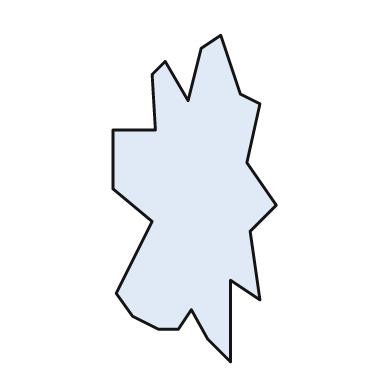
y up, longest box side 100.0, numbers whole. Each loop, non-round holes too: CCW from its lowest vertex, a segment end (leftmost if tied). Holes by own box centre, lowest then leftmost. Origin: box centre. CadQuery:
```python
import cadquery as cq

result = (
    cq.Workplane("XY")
    .moveTo(11.0, -50.0)
    .lineTo(11.0, -25.0)
    .lineTo(20.0, -31.0)
    .lineTo(17.0, -10.0)
    .lineTo(25.0, -2.0)
    .lineTo(16.0, 11.0)
    .lineTo(20.0, 29.0)
    .lineTo(14.0, 32.0)
    .lineTo(8.0, 50.0)
    .lineTo(2.0, 46.0)
    .lineTo(-2.0, 30.0)
    .lineTo(-9.0, 42.0)
    .lineTo(-13.0, 38.0)
    .lineTo(-12.0, 21.0)
    .lineTo(-25.0, 21.0)
    .lineTo(-25.0, 3.0)
    .lineTo(-13.0, -7.0)
    .lineTo(-24.0, -29.0)
    .lineTo(-19.0, -36.0)
    .lineTo(-11.0, -40.0)
    .lineTo(-5.0, -40.0)
    .lineTo(-1.0, -34.0)
    .lineTo(4.0, -43.0)
    .close()
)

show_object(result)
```